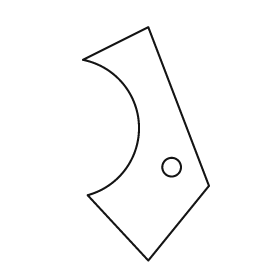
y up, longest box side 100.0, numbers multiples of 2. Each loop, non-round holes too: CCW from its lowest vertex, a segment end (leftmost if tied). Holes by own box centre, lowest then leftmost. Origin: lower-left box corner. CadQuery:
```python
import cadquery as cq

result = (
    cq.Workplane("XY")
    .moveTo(28.0, 0.0)
    .lineTo(54.0, 32.0)
    .lineTo(28.0, 100.0)
    .lineTo(0.0, 86.0)
    .threePointArc((24.0, 58.0), (2.0, 28.0))
    .close()
    .moveTo(38.0, 40.0)
    .circle(4.0)
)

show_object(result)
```